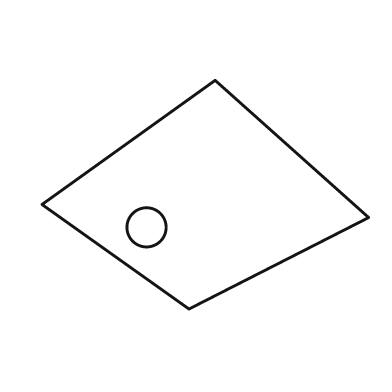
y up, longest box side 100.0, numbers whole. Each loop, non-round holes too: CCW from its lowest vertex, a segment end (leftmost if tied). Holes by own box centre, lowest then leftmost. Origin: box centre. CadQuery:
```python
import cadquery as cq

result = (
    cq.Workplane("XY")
    .moveTo(-5.0, -35.0)
    .lineTo(50.0, -7.0)
    .lineTo(3.0, 35.0)
    .lineTo(-50.0, -3.0)
    .close()
    .moveTo(-18.0, -10.0)
    .circle(6.0)
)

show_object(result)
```